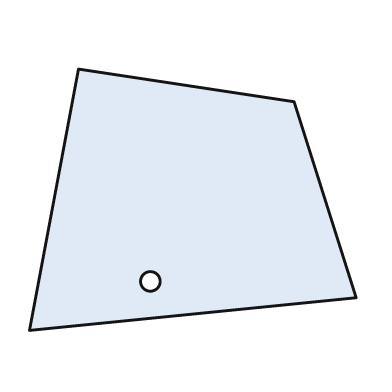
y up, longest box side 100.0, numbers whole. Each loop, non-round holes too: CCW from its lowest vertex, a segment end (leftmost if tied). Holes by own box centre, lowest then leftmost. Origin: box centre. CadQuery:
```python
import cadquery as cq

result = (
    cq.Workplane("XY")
    .moveTo(-50.0, -40.0)
    .lineTo(50.0, -30.0)
    .lineTo(31.0, 30.0)
    .lineTo(-35.0, 40.0)
    .close()
    .moveTo(-13.0, -25.0)
    .circle(3.0)
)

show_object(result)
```